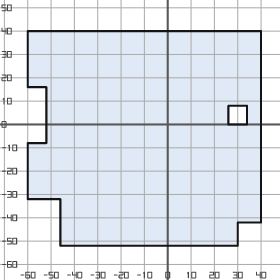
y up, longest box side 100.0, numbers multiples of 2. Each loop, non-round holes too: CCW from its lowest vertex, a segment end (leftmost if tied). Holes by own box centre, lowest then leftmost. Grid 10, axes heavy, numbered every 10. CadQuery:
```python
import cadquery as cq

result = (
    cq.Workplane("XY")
    .moveTo(-46.0, -52.0)
    .lineTo(30.0, -52.0)
    .lineTo(30.0, -42.0)
    .lineTo(40.0, -42.0)
    .lineTo(40.0, 40.0)
    .lineTo(-60.0, 40.0)
    .lineTo(-60.0, 16.0)
    .lineTo(-52.0, 16.0)
    .lineTo(-52.0, -8.0)
    .lineTo(-60.0, -8.0)
    .lineTo(-60.0, -32.0)
    .lineTo(-46.0, -32.0)
    .close()
    .moveTo(26.0, 0.0)
    .lineTo(34.0, 0.0)
    .lineTo(34.0, 8.0)
    .lineTo(26.0, 8.0)
    .close()
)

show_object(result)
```